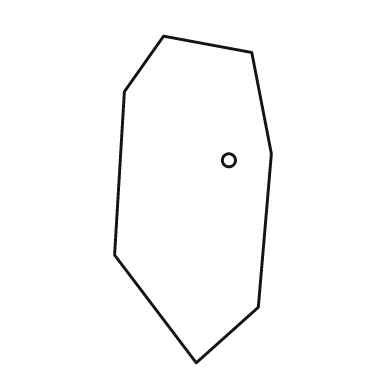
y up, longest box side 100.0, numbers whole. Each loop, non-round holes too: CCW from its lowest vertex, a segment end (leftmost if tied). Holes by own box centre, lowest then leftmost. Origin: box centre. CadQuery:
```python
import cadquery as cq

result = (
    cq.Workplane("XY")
    .moveTo(1.0, -50.0)
    .lineTo(20.0, -33.0)
    .lineTo(24.0, 14.0)
    .lineTo(18.0, 45.0)
    .lineTo(-9.0, 50.0)
    .lineTo(-21.0, 33.0)
    .lineTo(-24.0, -17.0)
    .close()
    .moveTo(11.0, 12.0)
    .circle(2.0)
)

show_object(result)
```